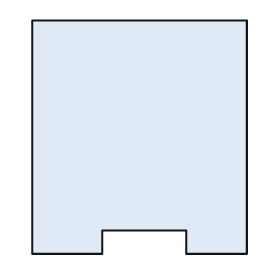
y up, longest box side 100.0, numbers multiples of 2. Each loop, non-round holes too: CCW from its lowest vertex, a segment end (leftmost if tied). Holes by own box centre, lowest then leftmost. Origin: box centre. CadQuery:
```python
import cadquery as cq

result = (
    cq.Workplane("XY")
    .moveTo(-46.0, -50.0)
    .lineTo(-16.0, -50.0)
    .lineTo(-16.0, -40.0)
    .lineTo(20.0, -40.0)
    .lineTo(20.0, -50.0)
    .lineTo(46.0, -50.0)
    .lineTo(46.0, 50.0)
    .lineTo(-46.0, 50.0)
    .close()
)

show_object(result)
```